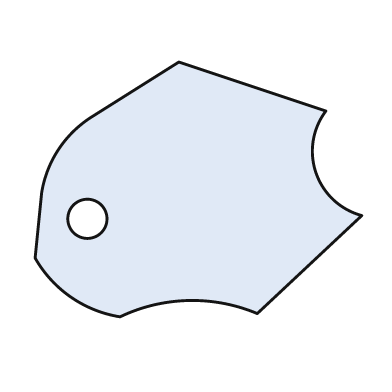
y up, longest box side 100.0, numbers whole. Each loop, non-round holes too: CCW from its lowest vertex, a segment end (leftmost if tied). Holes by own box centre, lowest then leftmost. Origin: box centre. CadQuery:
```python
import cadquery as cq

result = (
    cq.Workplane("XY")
    .moveTo(-24.0, -39.0)
    .threePointArc((-3.0, -34.0), (18.0, -38.0))
    .lineTo(50.0, -8.0)
    .threePointArc((36.0, 5.0), (39.0, 24.0))
    .lineTo(-6.0, 39.0)
    .lineTo(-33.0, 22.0)
    .threePointArc((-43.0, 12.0), (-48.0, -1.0))
    .lineTo(-50.0, -21.0)
    .threePointArc((-39.0, -33.0), (-24.0, -39.0))
    .close()
    .moveTo(-34.0, -9.0)
    .circle(6.0)
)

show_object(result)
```